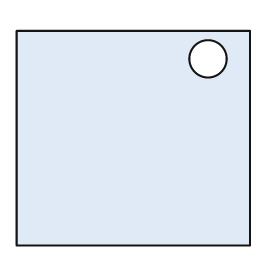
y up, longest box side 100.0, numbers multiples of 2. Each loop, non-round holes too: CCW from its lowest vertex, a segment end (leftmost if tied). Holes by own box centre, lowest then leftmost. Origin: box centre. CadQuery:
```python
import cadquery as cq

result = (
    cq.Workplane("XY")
    .moveTo(-50.0, -46.0)
    .lineTo(50.0, -46.0)
    .lineTo(50.0, 46.0)
    .lineTo(-50.0, 46.0)
    .close()
    .moveTo(32.0, 34.0)
    .circle(8.0)
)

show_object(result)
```